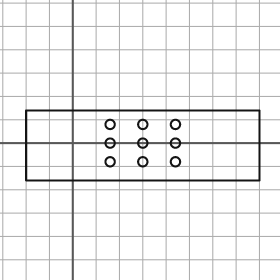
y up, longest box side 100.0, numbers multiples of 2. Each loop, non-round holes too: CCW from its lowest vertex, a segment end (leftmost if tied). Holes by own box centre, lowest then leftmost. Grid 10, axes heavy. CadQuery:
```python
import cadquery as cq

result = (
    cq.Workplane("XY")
    .moveTo(-20.0, -16.0)
    .lineTo(80.0, -16.0)
    .lineTo(80.0, 14.0)
    .lineTo(-20.0, 14.0)
    .close()
    .moveTo(16.0, -8.0)
    .circle(2.0)
    .moveTo(30.0, -8.0)
    .circle(2.0)
    .moveTo(44.0, -8.0)
    .circle(2.0)
    .moveTo(16.0, 0.0)
    .circle(2.0)
    .moveTo(30.0, 0.0)
    .circle(2.0)
    .moveTo(44.0, 0.0)
    .circle(2.0)
    .moveTo(16.0, 8.0)
    .circle(2.0)
    .moveTo(30.0, 8.0)
    .circle(2.0)
    .moveTo(44.0, 8.0)
    .circle(2.0)
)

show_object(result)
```